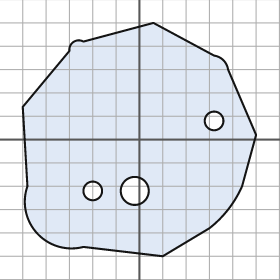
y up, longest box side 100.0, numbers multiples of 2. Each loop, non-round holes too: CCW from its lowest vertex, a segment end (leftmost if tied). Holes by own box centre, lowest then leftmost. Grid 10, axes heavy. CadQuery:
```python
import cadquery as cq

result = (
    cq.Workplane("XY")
    .moveTo(10.0, -50.0)
    .lineTo(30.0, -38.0)
    .threePointArc((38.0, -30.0), (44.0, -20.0))
    .lineTo(50.0, 2.0)
    .lineTo(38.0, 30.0)
    .threePointArc((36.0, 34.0), (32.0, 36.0))
    .lineTo(6.0, 50.0)
    .lineTo(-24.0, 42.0)
    .threePointArc((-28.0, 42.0), (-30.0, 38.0))
    .lineTo(-50.0, 14.0)
    .lineTo(-48.0, -20.0)
    .threePointArc((-44.0, -40.0), (-24.0, -46.0))
    .close()
    .moveTo(-20.0, -22.0)
    .circle(4.0)
    .moveTo(-2.0, -22.0)
    .circle(6.0)
    .moveTo(32.0, 8.0)
    .circle(4.0)
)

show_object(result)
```